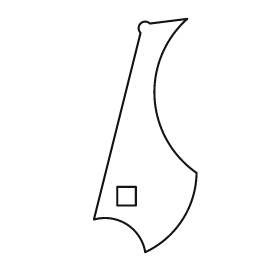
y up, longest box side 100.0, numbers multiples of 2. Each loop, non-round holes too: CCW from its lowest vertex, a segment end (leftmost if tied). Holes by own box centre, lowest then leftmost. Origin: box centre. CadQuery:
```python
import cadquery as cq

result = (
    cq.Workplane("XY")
    .moveTo(0.0, -50.0)
    .threePointArc((16.0, -36.0), (22.0, -16.0))
    .threePointArc((4.0, 16.0), (18.0, 50.0))
    .lineTo(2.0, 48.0)
    .threePointArc((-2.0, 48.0), (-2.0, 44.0))
    .lineTo(-22.0, -36.0)
    .threePointArc((-8.0, -38.0), (0.0, -50.0))
    .close()
    .moveTo(-12.0, -30.0)
    .lineTo(-4.0, -30.0)
    .lineTo(-4.0, -22.0)
    .lineTo(-12.0, -22.0)
    .close()
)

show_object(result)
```